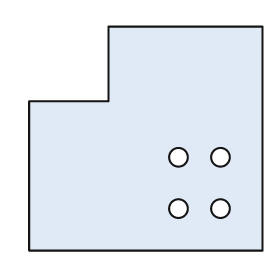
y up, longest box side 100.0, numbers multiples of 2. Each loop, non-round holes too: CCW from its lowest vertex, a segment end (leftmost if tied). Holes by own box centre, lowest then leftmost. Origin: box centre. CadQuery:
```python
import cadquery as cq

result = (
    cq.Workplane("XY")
    .moveTo(-50.0, -48.0)
    .lineTo(50.0, -48.0)
    .lineTo(50.0, 48.0)
    .lineTo(-16.0, 48.0)
    .lineTo(-16.0, 16.0)
    .lineTo(-50.0, 16.0)
    .close()
    .moveTo(14.0, -30.0)
    .circle(4.0)
    .moveTo(32.0, -30.0)
    .circle(4.0)
    .moveTo(14.0, -8.0)
    .circle(4.0)
    .moveTo(32.0, -8.0)
    .circle(4.0)
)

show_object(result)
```